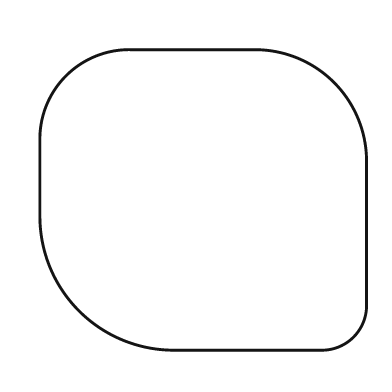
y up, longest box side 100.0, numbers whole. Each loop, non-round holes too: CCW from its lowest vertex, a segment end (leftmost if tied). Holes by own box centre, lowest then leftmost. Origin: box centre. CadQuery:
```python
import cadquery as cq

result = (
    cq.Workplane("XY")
    .moveTo(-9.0, -46.0)
    .lineTo(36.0, -46.0)
    .threePointArc((46.0, -42.0), (50.0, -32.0))
    .lineTo(50.0, 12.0)
    .threePointArc((40.0, 36.0), (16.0, 46.0))
    .lineTo(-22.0, 46.0)
    .threePointArc((-42.0, 38.0), (-50.0, 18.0))
    .lineTo(-50.0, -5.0)
    .threePointArc((-38.0, -34.0), (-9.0, -46.0))
    .close()
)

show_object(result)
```